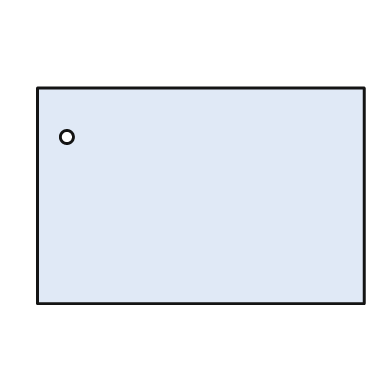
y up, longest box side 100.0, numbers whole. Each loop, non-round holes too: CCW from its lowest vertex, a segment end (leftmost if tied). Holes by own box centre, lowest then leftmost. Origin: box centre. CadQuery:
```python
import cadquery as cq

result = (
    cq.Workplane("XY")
    .moveTo(-50.0, -33.0)
    .lineTo(50.0, -33.0)
    .lineTo(50.0, 33.0)
    .lineTo(-50.0, 33.0)
    .close()
    .moveTo(-41.0, 18.0)
    .circle(2.0)
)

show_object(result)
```